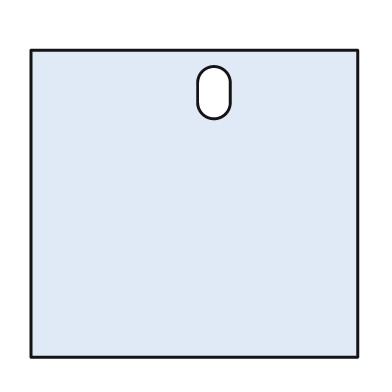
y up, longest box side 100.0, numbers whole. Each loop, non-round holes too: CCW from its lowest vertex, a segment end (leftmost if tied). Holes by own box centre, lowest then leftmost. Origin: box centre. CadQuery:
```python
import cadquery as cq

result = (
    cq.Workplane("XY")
    .moveTo(-50.0, -47.0)
    .lineTo(50.0, -47.0)
    .lineTo(50.0, 47.0)
    .lineTo(-50.0, 47.0)
    .close()
    .moveTo(1.0, 31.0)
    .threePointArc((6.0, 26.0), (11.0, 31.0))
    .lineTo(11.0, 37.0)
    .threePointArc((6.0, 42.0), (1.0, 37.0))
    .close()
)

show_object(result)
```